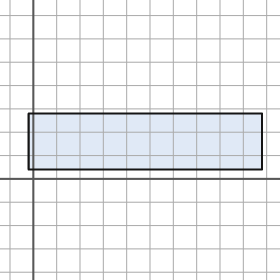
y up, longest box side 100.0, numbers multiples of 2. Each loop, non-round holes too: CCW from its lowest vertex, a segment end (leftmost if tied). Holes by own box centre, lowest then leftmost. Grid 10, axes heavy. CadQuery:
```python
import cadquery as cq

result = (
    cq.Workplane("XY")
    .moveTo(-2.0, 4.0)
    .lineTo(98.0, 4.0)
    .lineTo(98.0, 28.0)
    .lineTo(-2.0, 28.0)
    .close()
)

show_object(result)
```